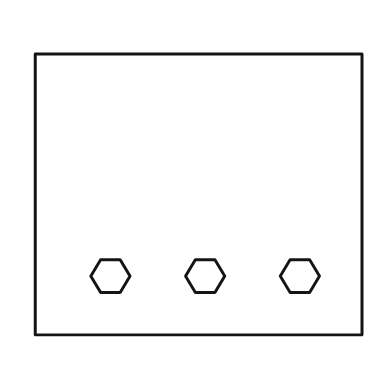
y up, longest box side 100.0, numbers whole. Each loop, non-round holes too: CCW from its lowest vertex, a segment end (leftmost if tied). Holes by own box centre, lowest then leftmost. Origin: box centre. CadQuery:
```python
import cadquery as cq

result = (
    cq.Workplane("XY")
    .moveTo(-50.0, -43.0)
    .lineTo(50.0, -43.0)
    .lineTo(50.0, 43.0)
    .lineTo(-50.0, 43.0)
    .close()
    .moveTo(-30.0, -30.0)
    .lineTo(-24.0, -30.0)
    .lineTo(-21.0, -25.0)
    .lineTo(-24.0, -20.0)
    .lineTo(-30.0, -20.0)
    .lineTo(-33.0, -25.0)
    .close()
    .moveTo(-1.0, -30.0)
    .lineTo(5.0, -30.0)
    .lineTo(8.0, -25.0)
    .lineTo(5.0, -20.0)
    .lineTo(-1.0, -20.0)
    .lineTo(-4.0, -25.0)
    .close()
    .moveTo(28.0, -30.0)
    .lineTo(34.0, -30.0)
    .lineTo(37.0, -25.0)
    .lineTo(34.0, -20.0)
    .lineTo(28.0, -20.0)
    .lineTo(25.0, -25.0)
    .close()
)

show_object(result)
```